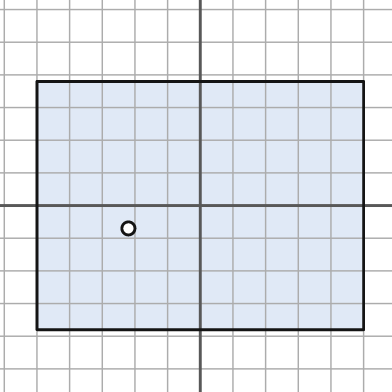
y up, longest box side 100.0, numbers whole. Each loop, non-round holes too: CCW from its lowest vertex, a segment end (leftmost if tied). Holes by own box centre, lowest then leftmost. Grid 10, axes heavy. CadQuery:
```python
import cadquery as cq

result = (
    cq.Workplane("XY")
    .moveTo(-50.0, -38.0)
    .lineTo(50.0, -38.0)
    .lineTo(50.0, 38.0)
    .lineTo(-50.0, 38.0)
    .close()
    .moveTo(-22.0, -7.0)
    .circle(2.0)
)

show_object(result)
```